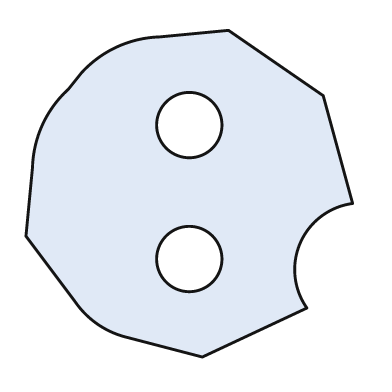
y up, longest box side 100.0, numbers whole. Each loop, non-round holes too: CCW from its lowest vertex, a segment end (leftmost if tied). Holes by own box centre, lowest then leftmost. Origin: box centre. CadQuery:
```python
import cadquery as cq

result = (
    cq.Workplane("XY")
    .moveTo(4.0, -50.0)
    .lineTo(36.0, -35.0)
    .threePointArc((34.0, -15.0), (50.0, -3.0))
    .lineTo(41.0, 30.0)
    .lineTo(12.0, 50.0)
    .lineTo(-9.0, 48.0)
    .threePointArc((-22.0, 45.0), (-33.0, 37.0))
    .lineTo(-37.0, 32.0)
    .threePointArc((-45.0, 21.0), (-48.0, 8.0))
    .lineTo(-50.0, -13.0)
    .lineTo(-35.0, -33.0)
    .threePointArc((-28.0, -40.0), (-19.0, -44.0))
    .close()
    .moveTo(0.0, -20.0)
    .circle(10.0)
    .moveTo(0.0, 21.0)
    .circle(10.0)
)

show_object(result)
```